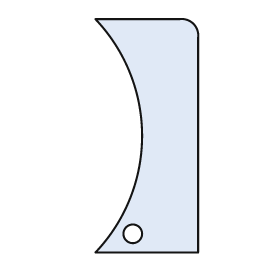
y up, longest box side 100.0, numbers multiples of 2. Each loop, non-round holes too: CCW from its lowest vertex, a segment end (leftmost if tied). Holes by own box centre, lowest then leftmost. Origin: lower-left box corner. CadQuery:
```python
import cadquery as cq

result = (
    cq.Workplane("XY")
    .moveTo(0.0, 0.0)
    .lineTo(44.0, 0.0)
    .lineTo(44.0, 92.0)
    .threePointArc((42.0, 98.0), (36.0, 100.0))
    .lineTo(0.0, 100.0)
    .threePointArc((20.0, 50.0), (0.0, 0.0))
    .close()
    .moveTo(16.0, 8.0)
    .circle(4.0)
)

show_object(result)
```